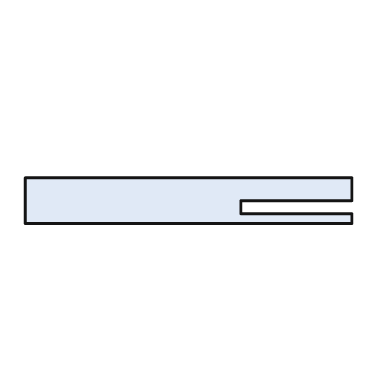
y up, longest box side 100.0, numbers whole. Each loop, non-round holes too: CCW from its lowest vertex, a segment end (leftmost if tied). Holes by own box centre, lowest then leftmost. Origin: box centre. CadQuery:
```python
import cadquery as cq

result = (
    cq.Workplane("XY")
    .moveTo(-50.0, -7.0)
    .lineTo(50.0, -7.0)
    .lineTo(50.0, -4.0)
    .lineTo(16.0, -4.0)
    .lineTo(16.0, 0.0)
    .lineTo(50.0, 0.0)
    .lineTo(50.0, 7.0)
    .lineTo(-50.0, 7.0)
    .close()
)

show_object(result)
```